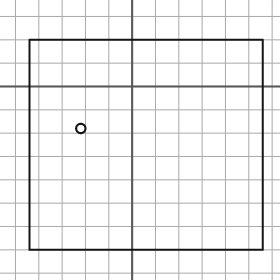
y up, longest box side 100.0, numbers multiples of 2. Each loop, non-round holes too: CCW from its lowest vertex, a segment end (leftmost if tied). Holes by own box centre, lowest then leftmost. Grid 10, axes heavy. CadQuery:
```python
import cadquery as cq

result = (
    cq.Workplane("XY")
    .moveTo(-44.0, -70.0)
    .lineTo(56.0, -70.0)
    .lineTo(56.0, 20.0)
    .lineTo(-44.0, 20.0)
    .close()
    .moveTo(-22.0, -18.0)
    .circle(2.0)
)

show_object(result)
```